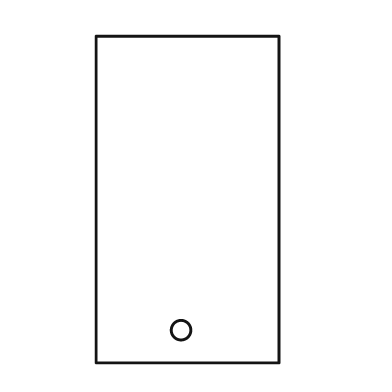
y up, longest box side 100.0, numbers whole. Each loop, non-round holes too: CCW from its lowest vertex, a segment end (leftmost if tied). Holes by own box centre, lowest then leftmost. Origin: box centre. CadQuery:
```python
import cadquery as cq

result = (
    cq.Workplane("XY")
    .moveTo(-28.0, -50.0)
    .lineTo(28.0, -50.0)
    .lineTo(28.0, 50.0)
    .lineTo(-28.0, 50.0)
    .close()
    .moveTo(-2.0, -40.0)
    .circle(3.0)
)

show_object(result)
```